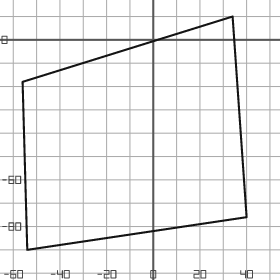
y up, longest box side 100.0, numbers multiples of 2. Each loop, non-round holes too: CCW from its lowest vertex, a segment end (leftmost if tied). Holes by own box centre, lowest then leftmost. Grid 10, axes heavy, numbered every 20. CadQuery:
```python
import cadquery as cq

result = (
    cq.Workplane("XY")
    .moveTo(-54.0, -90.0)
    .lineTo(40.0, -76.0)
    .lineTo(34.0, 10.0)
    .lineTo(-56.0, -18.0)
    .close()
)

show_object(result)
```